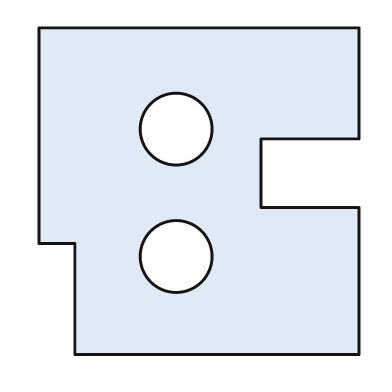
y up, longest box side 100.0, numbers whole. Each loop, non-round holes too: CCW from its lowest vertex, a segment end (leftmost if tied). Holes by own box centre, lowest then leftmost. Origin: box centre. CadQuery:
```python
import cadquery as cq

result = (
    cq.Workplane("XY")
    .moveTo(-38.0, -50.0)
    .lineTo(49.0, -50.0)
    .lineTo(49.0, -5.0)
    .lineTo(19.0, -5.0)
    .lineTo(19.0, 16.0)
    .lineTo(49.0, 16.0)
    .lineTo(49.0, 50.0)
    .lineTo(-49.0, 50.0)
    .lineTo(-49.0, -16.0)
    .lineTo(-38.0, -16.0)
    .close()
    .moveTo(-7.0, -20.0)
    .circle(11.0)
    .moveTo(-7.0, 19.0)
    .circle(11.0)
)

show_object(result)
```